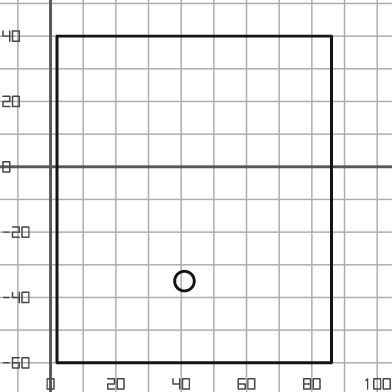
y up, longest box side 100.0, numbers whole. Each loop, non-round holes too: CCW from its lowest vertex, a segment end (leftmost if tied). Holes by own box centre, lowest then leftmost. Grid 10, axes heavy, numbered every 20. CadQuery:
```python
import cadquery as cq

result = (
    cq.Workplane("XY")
    .moveTo(2.0, -60.0)
    .lineTo(86.0, -60.0)
    .lineTo(86.0, 40.0)
    .lineTo(2.0, 40.0)
    .close()
    .moveTo(41.0, -35.0)
    .circle(3.0)
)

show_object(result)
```